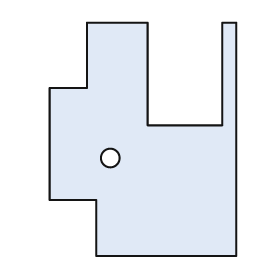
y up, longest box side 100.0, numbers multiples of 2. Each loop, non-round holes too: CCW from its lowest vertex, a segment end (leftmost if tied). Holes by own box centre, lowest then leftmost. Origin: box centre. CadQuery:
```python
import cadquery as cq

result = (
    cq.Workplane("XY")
    .moveTo(-20.0, -50.0)
    .lineTo(40.0, -50.0)
    .lineTo(40.0, 50.0)
    .lineTo(34.0, 50.0)
    .lineTo(34.0, 6.0)
    .lineTo(2.0, 6.0)
    .lineTo(2.0, 50.0)
    .lineTo(-24.0, 50.0)
    .lineTo(-24.0, 22.0)
    .lineTo(-40.0, 22.0)
    .lineTo(-40.0, -26.0)
    .lineTo(-20.0, -26.0)
    .close()
    .moveTo(-14.0, -8.0)
    .circle(4.0)
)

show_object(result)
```